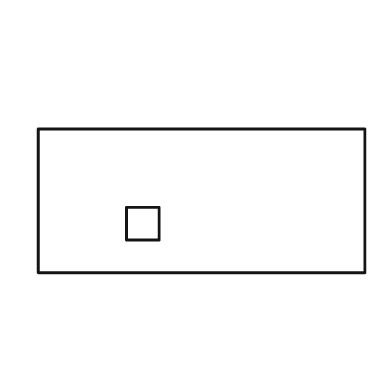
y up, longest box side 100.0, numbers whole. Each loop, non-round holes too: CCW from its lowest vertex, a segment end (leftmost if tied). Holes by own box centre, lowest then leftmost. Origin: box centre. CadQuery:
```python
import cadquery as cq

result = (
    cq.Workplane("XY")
    .moveTo(-50.0, -22.0)
    .lineTo(50.0, -22.0)
    .lineTo(50.0, 22.0)
    .lineTo(-50.0, 22.0)
    .close()
    .moveTo(-23.0, -12.0)
    .lineTo(-13.0, -12.0)
    .lineTo(-13.0, -2.0)
    .lineTo(-23.0, -2.0)
    .close()
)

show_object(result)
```